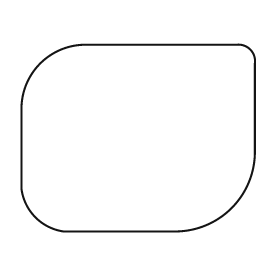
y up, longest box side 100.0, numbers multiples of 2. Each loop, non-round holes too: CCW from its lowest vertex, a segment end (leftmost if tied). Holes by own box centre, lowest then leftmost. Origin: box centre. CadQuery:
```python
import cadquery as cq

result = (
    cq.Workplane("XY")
    .moveTo(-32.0, -40.0)
    .lineTo(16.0, -40.0)
    .threePointArc((40.0, -30.0), (50.0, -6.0))
    .lineTo(50.0, 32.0)
    .threePointArc((48.0, 38.0), (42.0, 40.0))
    .lineTo(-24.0, 40.0)
    .threePointArc((-42.0, 32.0), (-50.0, 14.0))
    .lineTo(-50.0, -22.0)
    .threePointArc((-44.0, -34.0), (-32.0, -40.0))
    .close()
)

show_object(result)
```